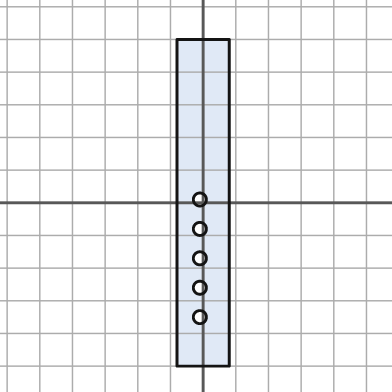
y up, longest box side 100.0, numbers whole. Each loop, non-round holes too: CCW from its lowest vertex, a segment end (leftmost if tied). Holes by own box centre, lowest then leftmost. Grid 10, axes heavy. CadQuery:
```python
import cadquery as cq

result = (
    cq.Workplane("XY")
    .moveTo(-8.0, -50.0)
    .lineTo(8.0, -50.0)
    .lineTo(8.0, 50.0)
    .lineTo(-8.0, 50.0)
    .close()
    .moveTo(-1.0, -35.0)
    .circle(2.0)
    .moveTo(-1.0, -26.0)
    .circle(2.0)
    .moveTo(-1.0, -17.0)
    .circle(2.0)
    .moveTo(-1.0, -8.0)
    .circle(2.0)
    .moveTo(-1.0, 1.0)
    .circle(2.0)
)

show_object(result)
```